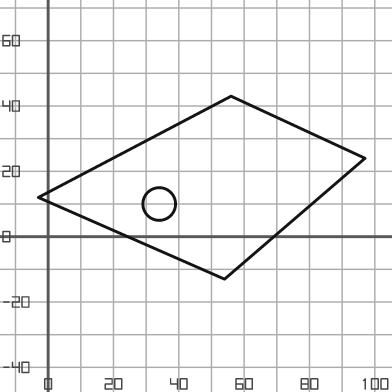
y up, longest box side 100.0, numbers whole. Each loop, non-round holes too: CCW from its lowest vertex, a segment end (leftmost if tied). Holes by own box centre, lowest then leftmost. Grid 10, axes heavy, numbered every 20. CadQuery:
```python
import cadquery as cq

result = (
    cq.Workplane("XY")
    .moveTo(54.0, -13.0)
    .lineTo(97.0, 24.0)
    .lineTo(56.0, 43.0)
    .lineTo(-3.0, 12.0)
    .close()
    .moveTo(34.0, 10.0)
    .circle(5.0)
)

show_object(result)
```